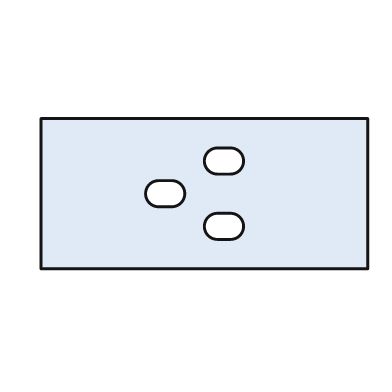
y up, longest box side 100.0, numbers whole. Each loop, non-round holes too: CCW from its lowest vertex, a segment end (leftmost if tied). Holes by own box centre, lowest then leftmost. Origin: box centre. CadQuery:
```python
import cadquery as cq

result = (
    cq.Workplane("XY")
    .moveTo(-50.0, -23.0)
    .lineTo(50.0, -23.0)
    .lineTo(50.0, 23.0)
    .lineTo(-50.0, 23.0)
    .close()
    .moveTo(4.0, -14.0)
    .lineTo(8.0, -14.0)
    .threePointArc((12.0, -10.0), (8.0, -6.0))
    .lineTo(4.0, -6.0)
    .threePointArc((0.0, -10.0), (4.0, -14.0))
    .close()
    .moveTo(-14.0, -4.0)
    .lineTo(-10.0, -4.0)
    .threePointArc((-6.0, 0.0), (-10.0, 4.0))
    .lineTo(-14.0, 4.0)
    .threePointArc((-18.0, 0.0), (-14.0, -4.0))
    .close()
    .moveTo(4.0, 6.0)
    .lineTo(8.0, 6.0)
    .threePointArc((12.0, 10.0), (8.0, 14.0))
    .lineTo(4.0, 14.0)
    .threePointArc((0.0, 10.0), (4.0, 6.0))
    .close()
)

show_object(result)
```